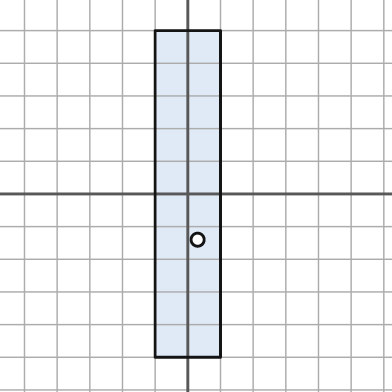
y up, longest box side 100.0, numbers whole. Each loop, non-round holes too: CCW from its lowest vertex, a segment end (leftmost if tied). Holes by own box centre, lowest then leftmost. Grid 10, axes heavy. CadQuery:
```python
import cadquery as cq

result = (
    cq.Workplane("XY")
    .moveTo(-10.0, -50.0)
    .lineTo(10.0, -50.0)
    .lineTo(10.0, 50.0)
    .lineTo(-10.0, 50.0)
    .close()
    .moveTo(3.0, -14.0)
    .circle(2.0)
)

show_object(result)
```